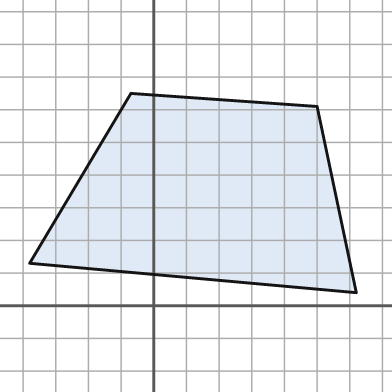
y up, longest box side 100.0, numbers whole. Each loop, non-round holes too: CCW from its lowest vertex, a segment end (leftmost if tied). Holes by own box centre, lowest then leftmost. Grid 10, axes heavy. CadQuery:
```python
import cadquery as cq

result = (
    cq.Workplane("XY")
    .moveTo(62.0, 4.0)
    .lineTo(50.0, 61.0)
    .lineTo(-7.0, 65.0)
    .lineTo(-38.0, 13.0)
    .close()
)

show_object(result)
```